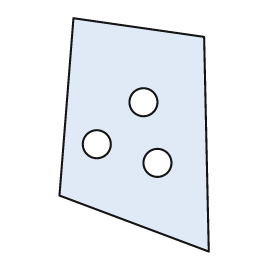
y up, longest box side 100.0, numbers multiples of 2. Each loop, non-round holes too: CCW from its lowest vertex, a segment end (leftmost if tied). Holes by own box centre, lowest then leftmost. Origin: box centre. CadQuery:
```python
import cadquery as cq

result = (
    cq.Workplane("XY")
    .moveTo(32.0, -50.0)
    .lineTo(30.0, 42.0)
    .lineTo(-26.0, 50.0)
    .lineTo(-32.0, -26.0)
    .close()
    .moveTo(10.0, -12.0)
    .circle(6.0)
    .moveTo(-16.0, -4.0)
    .circle(6.0)
    .moveTo(4.0, 14.0)
    .circle(6.0)
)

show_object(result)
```